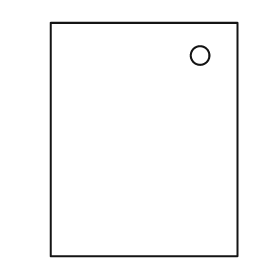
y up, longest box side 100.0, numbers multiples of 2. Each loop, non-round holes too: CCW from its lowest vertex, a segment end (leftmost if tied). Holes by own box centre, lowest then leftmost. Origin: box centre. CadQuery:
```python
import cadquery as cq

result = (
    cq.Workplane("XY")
    .moveTo(-40.0, -50.0)
    .lineTo(40.0, -50.0)
    .lineTo(40.0, 50.0)
    .lineTo(-40.0, 50.0)
    .close()
    .moveTo(24.0, 36.0)
    .circle(4.0)
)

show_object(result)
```